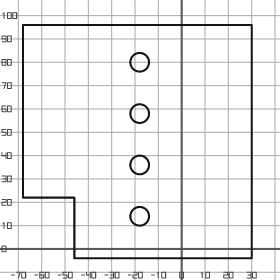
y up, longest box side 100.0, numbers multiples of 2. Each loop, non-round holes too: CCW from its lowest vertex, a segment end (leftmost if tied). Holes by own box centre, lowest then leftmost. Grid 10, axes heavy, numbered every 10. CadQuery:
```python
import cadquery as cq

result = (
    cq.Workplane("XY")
    .moveTo(-46.0, -4.0)
    .lineTo(30.0, -4.0)
    .lineTo(30.0, 96.0)
    .lineTo(-68.0, 96.0)
    .lineTo(-68.0, 22.0)
    .lineTo(-46.0, 22.0)
    .close()
    .moveTo(-18.0, 14.0)
    .circle(4.0)
    .moveTo(-18.0, 36.0)
    .circle(4.0)
    .moveTo(-18.0, 58.0)
    .circle(4.0)
    .moveTo(-18.0, 80.0)
    .circle(4.0)
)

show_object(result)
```